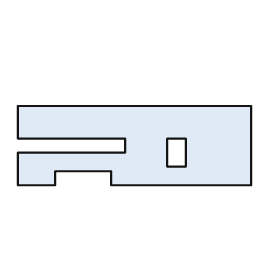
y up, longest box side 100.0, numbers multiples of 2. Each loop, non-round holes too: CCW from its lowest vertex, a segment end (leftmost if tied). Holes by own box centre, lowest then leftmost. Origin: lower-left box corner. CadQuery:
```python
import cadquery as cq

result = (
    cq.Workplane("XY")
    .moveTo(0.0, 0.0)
    .lineTo(16.0, 0.0)
    .lineTo(16.0, 6.0)
    .lineTo(40.0, 6.0)
    .lineTo(40.0, 0.0)
    .lineTo(100.0, 0.0)
    .lineTo(100.0, 34.0)
    .lineTo(0.0, 34.0)
    .lineTo(0.0, 20.0)
    .lineTo(46.0, 20.0)
    .lineTo(46.0, 14.0)
    .lineTo(0.0, 14.0)
    .close()
    .moveTo(64.0, 8.0)
    .lineTo(72.0, 8.0)
    .lineTo(72.0, 20.0)
    .lineTo(64.0, 20.0)
    .close()
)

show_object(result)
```